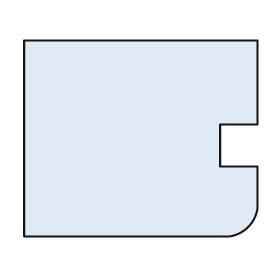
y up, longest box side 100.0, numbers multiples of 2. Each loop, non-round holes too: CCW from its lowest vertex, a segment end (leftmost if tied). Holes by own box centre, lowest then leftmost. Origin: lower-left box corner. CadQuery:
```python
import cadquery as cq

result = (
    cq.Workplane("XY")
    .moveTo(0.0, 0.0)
    .lineTo(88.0, 0.0)
    .threePointArc((96.0, 4.0), (100.0, 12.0))
    .lineTo(100.0, 30.0)
    .lineTo(84.0, 30.0)
    .lineTo(84.0, 48.0)
    .lineTo(100.0, 48.0)
    .lineTo(100.0, 84.0)
    .lineTo(0.0, 84.0)
    .close()
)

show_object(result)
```